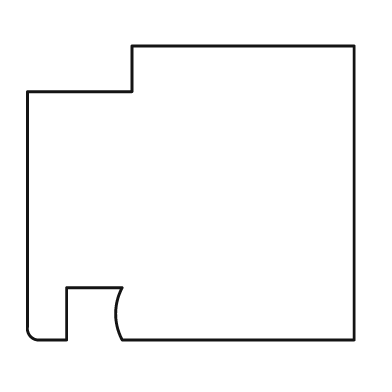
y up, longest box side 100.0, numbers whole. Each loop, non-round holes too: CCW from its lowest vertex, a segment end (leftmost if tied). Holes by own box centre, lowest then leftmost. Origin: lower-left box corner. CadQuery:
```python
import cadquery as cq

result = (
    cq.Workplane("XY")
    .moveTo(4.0, 0.0)
    .lineTo(12.0, 0.0)
    .lineTo(12.0, 16.0)
    .lineTo(29.0, 16.0)
    .threePointArc((27.0, 8.0), (29.0, 0.0))
    .lineTo(100.0, 0.0)
    .lineTo(100.0, 90.0)
    .lineTo(32.0, 90.0)
    .lineTo(32.0, 76.0)
    .lineTo(0.0, 76.0)
    .lineTo(0.0, 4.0)
    .threePointArc((1.0, 1.0), (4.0, 0.0))
    .close()
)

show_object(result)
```